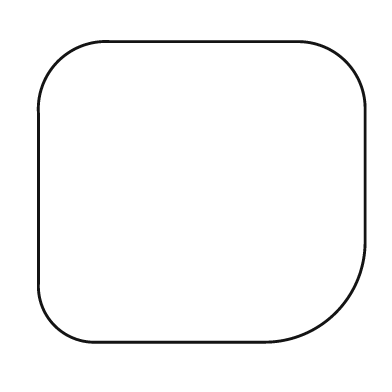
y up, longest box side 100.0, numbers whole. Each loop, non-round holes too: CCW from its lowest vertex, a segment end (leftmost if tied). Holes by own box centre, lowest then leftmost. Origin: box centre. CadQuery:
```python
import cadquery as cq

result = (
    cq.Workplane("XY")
    .moveTo(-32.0, -46.0)
    .lineTo(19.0, -46.0)
    .threePointArc((41.0, -37.0), (50.0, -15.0))
    .lineTo(50.0, 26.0)
    .threePointArc((44.0, 40.0), (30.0, 46.0))
    .lineTo(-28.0, 46.0)
    .threePointArc((-44.0, 40.0), (-50.0, 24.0))
    .lineTo(-50.0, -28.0)
    .threePointArc((-45.0, -41.0), (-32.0, -46.0))
    .close()
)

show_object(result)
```